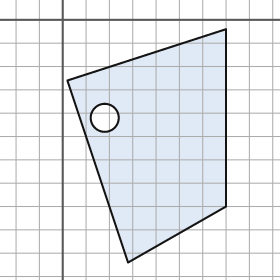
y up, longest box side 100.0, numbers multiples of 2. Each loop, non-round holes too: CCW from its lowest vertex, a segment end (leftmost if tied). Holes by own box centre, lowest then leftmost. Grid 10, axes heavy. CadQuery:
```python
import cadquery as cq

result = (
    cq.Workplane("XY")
    .moveTo(28.0, -104.0)
    .lineTo(70.0, -80.0)
    .lineTo(70.0, -4.0)
    .lineTo(2.0, -26.0)
    .close()
    .moveTo(18.0, -42.0)
    .circle(6.0)
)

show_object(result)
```